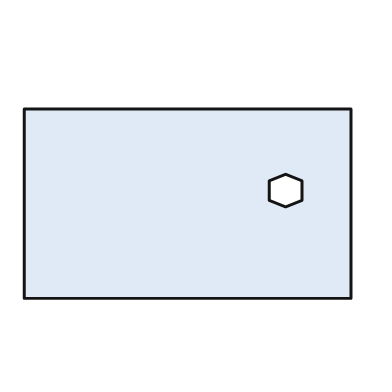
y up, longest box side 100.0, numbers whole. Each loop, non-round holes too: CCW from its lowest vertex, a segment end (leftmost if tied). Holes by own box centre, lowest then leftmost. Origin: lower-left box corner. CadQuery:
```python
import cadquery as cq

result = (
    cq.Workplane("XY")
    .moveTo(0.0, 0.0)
    .lineTo(100.0, 0.0)
    .lineTo(100.0, 58.0)
    .lineTo(0.0, 58.0)
    .close()
    .moveTo(80.0, 28.0)
    .lineTo(85.0, 30.0)
    .lineTo(85.0, 36.0)
    .lineTo(80.0, 38.0)
    .lineTo(75.0, 36.0)
    .lineTo(75.0, 30.0)
    .close()
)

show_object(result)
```